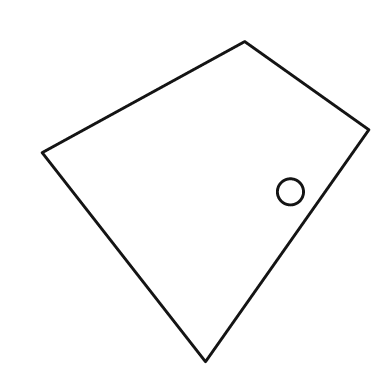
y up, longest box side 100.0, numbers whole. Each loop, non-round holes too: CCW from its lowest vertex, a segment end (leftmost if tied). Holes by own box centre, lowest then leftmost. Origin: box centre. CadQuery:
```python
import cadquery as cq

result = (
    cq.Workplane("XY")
    .moveTo(0.0, -49.0)
    .lineTo(50.0, 22.0)
    .lineTo(12.0, 49.0)
    .lineTo(-50.0, 15.0)
    .close()
    .moveTo(26.0, 3.0)
    .circle(4.0)
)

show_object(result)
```